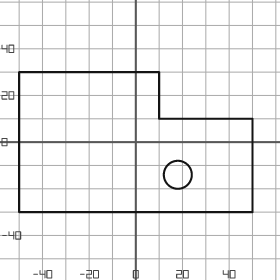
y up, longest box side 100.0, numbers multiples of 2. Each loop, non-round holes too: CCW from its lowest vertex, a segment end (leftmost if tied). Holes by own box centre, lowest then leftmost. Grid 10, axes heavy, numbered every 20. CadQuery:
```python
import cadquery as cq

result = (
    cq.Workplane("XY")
    .moveTo(-50.0, -30.0)
    .lineTo(50.0, -30.0)
    .lineTo(50.0, 10.0)
    .lineTo(10.0, 10.0)
    .lineTo(10.0, 30.0)
    .lineTo(-50.0, 30.0)
    .close()
    .moveTo(18.0, -14.0)
    .circle(6.0)
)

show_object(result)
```